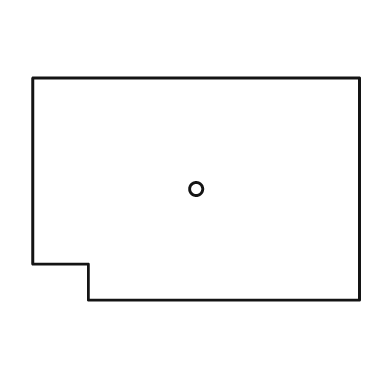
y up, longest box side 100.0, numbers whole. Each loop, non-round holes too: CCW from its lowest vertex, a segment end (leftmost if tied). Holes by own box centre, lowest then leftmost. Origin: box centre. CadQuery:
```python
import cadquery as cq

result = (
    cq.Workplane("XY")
    .moveTo(-33.0, -34.0)
    .lineTo(50.0, -34.0)
    .lineTo(50.0, 34.0)
    .lineTo(-50.0, 34.0)
    .lineTo(-50.0, -23.0)
    .lineTo(-33.0, -23.0)
    .close()
    .moveTo(0.0, 0.0)
    .circle(2.0)
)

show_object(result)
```